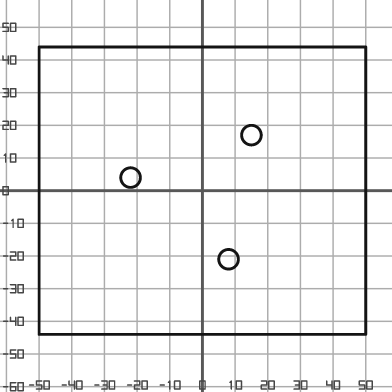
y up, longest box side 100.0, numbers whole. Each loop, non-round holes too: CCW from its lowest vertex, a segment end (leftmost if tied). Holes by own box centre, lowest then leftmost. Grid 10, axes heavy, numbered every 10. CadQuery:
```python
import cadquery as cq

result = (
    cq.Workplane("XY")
    .moveTo(-50.0, -44.0)
    .lineTo(50.0, -44.0)
    .lineTo(50.0, 44.0)
    .lineTo(-50.0, 44.0)
    .close()
    .moveTo(8.0, -21.0)
    .circle(3.0)
    .moveTo(-22.0, 4.0)
    .circle(3.0)
    .moveTo(15.0, 17.0)
    .circle(3.0)
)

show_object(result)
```